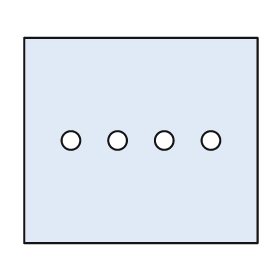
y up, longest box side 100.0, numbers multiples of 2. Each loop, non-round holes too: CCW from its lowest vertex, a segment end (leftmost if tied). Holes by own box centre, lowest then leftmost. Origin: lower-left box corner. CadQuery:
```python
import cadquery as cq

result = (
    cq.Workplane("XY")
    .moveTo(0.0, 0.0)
    .lineTo(100.0, 0.0)
    .lineTo(100.0, 88.0)
    .lineTo(0.0, 88.0)
    .close()
    .moveTo(20.0, 44.0)
    .circle(4.0)
    .moveTo(40.0, 44.0)
    .circle(4.0)
    .moveTo(60.0, 44.0)
    .circle(4.0)
    .moveTo(80.0, 44.0)
    .circle(4.0)
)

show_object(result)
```